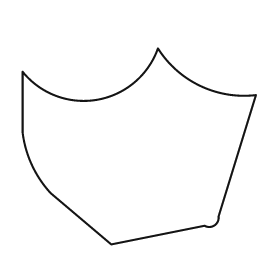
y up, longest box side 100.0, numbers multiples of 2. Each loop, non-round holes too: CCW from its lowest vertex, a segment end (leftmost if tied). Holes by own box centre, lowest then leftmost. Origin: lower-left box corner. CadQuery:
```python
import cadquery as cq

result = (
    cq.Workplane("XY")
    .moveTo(38.0, 0.0)
    .lineTo(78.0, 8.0)
    .threePointArc((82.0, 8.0), (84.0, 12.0))
    .lineTo(100.0, 64.0)
    .threePointArc((76.0, 68.0), (58.0, 84.0))
    .threePointArc((32.0, 62.0), (0.0, 74.0))
    .lineTo(0.0, 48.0)
    .threePointArc((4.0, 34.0), (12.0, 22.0))
    .close()
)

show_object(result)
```